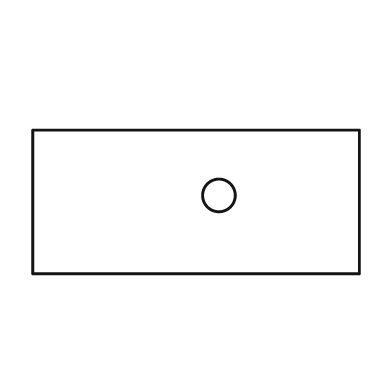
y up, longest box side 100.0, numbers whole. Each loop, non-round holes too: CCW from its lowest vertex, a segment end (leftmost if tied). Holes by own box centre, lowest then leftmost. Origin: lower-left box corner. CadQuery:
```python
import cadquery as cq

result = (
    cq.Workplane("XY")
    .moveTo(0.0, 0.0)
    .lineTo(100.0, 0.0)
    .lineTo(100.0, 44.0)
    .lineTo(0.0, 44.0)
    .close()
    .moveTo(57.0, 24.0)
    .circle(5.0)
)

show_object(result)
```